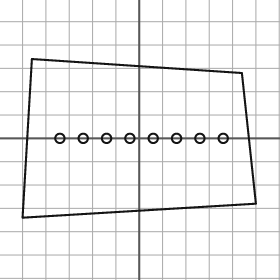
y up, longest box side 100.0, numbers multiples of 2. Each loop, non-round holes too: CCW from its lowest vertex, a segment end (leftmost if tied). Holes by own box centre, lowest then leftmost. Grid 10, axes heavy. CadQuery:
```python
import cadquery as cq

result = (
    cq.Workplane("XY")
    .moveTo(-50.0, -34.0)
    .lineTo(50.0, -28.0)
    .lineTo(44.0, 28.0)
    .lineTo(-46.0, 34.0)
    .close()
    .moveTo(-34.0, 0.0)
    .circle(2.0)
    .moveTo(-24.0, 0.0)
    .circle(2.0)
    .moveTo(-14.0, 0.0)
    .circle(2.0)
    .moveTo(-4.0, 0.0)
    .circle(2.0)
    .moveTo(6.0, 0.0)
    .circle(2.0)
    .moveTo(16.0, 0.0)
    .circle(2.0)
    .moveTo(26.0, 0.0)
    .circle(2.0)
    .moveTo(36.0, 0.0)
    .circle(2.0)
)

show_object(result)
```